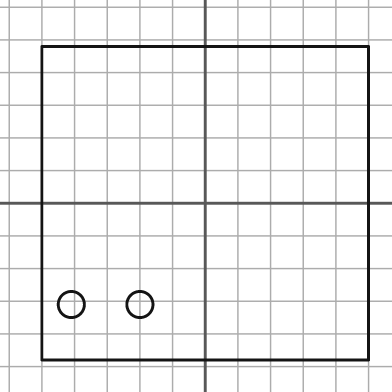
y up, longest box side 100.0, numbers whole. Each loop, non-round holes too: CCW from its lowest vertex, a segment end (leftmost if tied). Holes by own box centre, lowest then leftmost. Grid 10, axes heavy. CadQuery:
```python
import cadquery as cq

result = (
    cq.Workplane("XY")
    .moveTo(-50.0, -48.0)
    .lineTo(50.0, -48.0)
    .lineTo(50.0, 48.0)
    .lineTo(-50.0, 48.0)
    .close()
    .moveTo(-41.0, -31.0)
    .circle(4.0)
    .moveTo(-20.0, -31.0)
    .circle(4.0)
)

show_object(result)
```